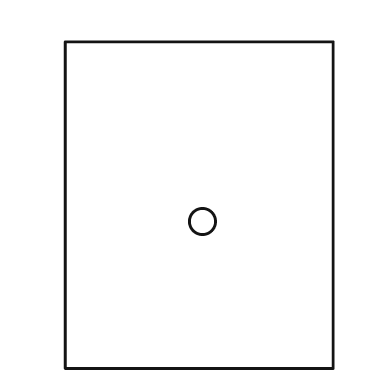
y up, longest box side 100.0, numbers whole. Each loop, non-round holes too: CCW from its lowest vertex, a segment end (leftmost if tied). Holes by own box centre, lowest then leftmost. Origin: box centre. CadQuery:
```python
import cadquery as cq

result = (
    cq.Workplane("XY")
    .moveTo(-41.0, -50.0)
    .lineTo(41.0, -50.0)
    .lineTo(41.0, 50.0)
    .lineTo(-41.0, 50.0)
    .close()
    .moveTo(1.0, -5.0)
    .circle(4.0)
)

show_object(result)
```